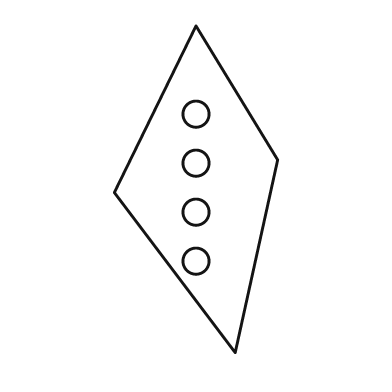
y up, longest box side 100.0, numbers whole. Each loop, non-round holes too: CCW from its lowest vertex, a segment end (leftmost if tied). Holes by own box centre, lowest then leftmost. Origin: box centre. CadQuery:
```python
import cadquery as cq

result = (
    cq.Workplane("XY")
    .moveTo(12.0, -50.0)
    .lineTo(25.0, 9.0)
    .lineTo(0.0, 50.0)
    .lineTo(-25.0, -1.0)
    .close()
    .moveTo(0.0, -22.0)
    .circle(4.0)
    .moveTo(0.0, -7.0)
    .circle(4.0)
    .moveTo(0.0, 8.0)
    .circle(4.0)
    .moveTo(0.0, 23.0)
    .circle(4.0)
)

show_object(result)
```